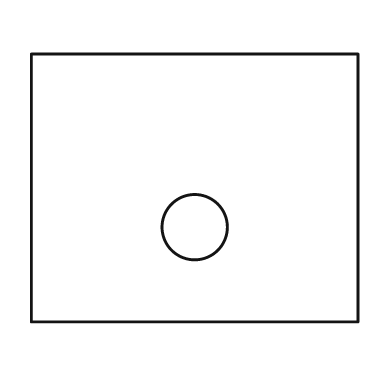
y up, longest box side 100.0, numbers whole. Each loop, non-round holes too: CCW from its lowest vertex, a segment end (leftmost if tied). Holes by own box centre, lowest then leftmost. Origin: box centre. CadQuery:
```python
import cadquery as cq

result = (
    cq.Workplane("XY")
    .moveTo(-50.0, -41.0)
    .lineTo(50.0, -41.0)
    .lineTo(50.0, 41.0)
    .lineTo(-50.0, 41.0)
    .close()
    .moveTo(0.0, -12.0)
    .circle(10.0)
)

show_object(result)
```